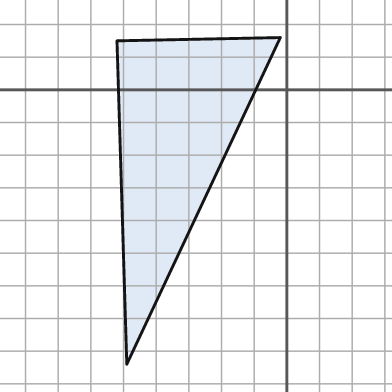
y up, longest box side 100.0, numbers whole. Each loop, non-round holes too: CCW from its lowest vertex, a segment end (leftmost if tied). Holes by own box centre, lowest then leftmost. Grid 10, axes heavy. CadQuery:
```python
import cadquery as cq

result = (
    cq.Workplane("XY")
    .moveTo(-49.0, -84.0)
    .lineTo(-2.0, 16.0)
    .lineTo(-52.0, 15.0)
    .close()
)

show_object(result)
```